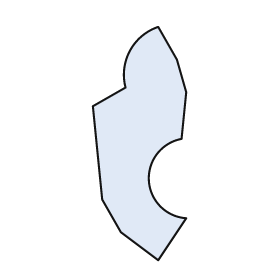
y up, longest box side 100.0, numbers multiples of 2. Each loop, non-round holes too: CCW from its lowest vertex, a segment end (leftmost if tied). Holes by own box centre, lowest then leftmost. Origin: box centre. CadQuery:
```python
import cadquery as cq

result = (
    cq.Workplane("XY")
    .moveTo(8.0, -50.0)
    .lineTo(20.0, -32.0)
    .threePointArc((4.0, -16.0), (18.0, 2.0))
    .lineTo(20.0, 22.0)
    .lineTo(16.0, 36.0)
    .lineTo(8.0, 50.0)
    .threePointArc((-4.0, 40.0), (-6.0, 24.0))
    .lineTo(-20.0, 16.0)
    .lineTo(-16.0, -24.0)
    .lineTo(-8.0, -38.0)
    .close()
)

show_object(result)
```